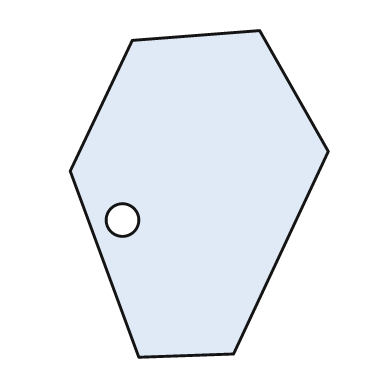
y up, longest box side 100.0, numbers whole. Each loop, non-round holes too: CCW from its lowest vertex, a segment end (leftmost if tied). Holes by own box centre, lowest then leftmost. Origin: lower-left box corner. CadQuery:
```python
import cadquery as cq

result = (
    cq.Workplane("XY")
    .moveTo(21.0, 0.0)
    .lineTo(50.0, 1.0)
    .lineTo(79.0, 63.0)
    .lineTo(58.0, 100.0)
    .lineTo(19.0, 97.0)
    .lineTo(0.0, 57.0)
    .close()
    .moveTo(16.0, 42.0)
    .circle(5.0)
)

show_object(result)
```